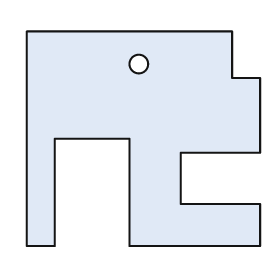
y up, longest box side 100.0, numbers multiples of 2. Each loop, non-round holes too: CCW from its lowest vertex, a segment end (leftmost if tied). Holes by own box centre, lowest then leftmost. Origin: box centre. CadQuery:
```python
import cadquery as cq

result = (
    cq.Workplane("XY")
    .moveTo(-50.0, -46.0)
    .lineTo(-38.0, -46.0)
    .lineTo(-38.0, 0.0)
    .lineTo(-6.0, 0.0)
    .lineTo(-6.0, -46.0)
    .lineTo(50.0, -46.0)
    .lineTo(50.0, -28.0)
    .lineTo(16.0, -28.0)
    .lineTo(16.0, -6.0)
    .lineTo(50.0, -6.0)
    .lineTo(50.0, 26.0)
    .lineTo(38.0, 26.0)
    .lineTo(38.0, 46.0)
    .lineTo(-50.0, 46.0)
    .close()
    .moveTo(-2.0, 32.0)
    .circle(4.0)
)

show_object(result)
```